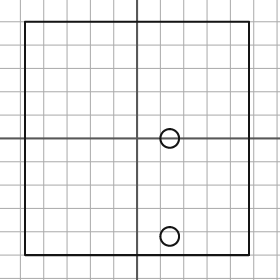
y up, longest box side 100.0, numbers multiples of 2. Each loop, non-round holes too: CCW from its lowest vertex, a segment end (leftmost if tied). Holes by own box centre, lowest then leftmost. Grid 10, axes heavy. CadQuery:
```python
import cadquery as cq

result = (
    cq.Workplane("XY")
    .moveTo(-48.0, -50.0)
    .lineTo(48.0, -50.0)
    .lineTo(48.0, 50.0)
    .lineTo(-48.0, 50.0)
    .close()
    .moveTo(14.0, -42.0)
    .circle(4.0)
    .moveTo(14.0, 0.0)
    .circle(4.0)
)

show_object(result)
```